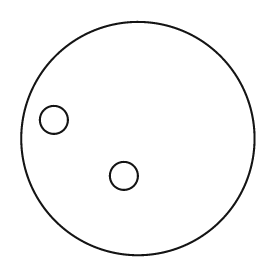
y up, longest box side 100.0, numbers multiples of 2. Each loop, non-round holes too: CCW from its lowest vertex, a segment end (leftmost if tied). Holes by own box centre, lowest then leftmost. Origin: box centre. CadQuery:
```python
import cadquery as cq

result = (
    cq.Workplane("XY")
    .moveTo(0.0, 0.0)
    .circle(50.0)
    .moveTo(-6.0, -16.0)
    .circle(6.0)
    .moveTo(-36.0, 8.0)
    .circle(6.0)
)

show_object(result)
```